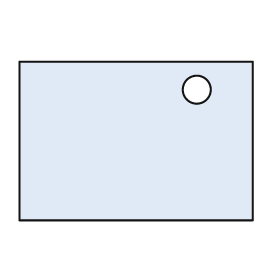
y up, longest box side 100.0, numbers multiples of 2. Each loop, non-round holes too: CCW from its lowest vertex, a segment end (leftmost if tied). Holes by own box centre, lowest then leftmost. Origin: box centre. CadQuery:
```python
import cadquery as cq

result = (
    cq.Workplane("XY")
    .moveTo(-50.0, -34.0)
    .lineTo(50.0, -34.0)
    .lineTo(50.0, 34.0)
    .lineTo(-50.0, 34.0)
    .close()
    .moveTo(26.0, 22.0)
    .circle(6.0)
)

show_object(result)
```